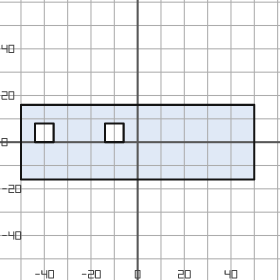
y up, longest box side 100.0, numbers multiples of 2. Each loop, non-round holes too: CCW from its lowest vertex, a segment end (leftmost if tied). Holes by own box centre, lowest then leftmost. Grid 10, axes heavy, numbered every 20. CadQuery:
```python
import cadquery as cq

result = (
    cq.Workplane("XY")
    .moveTo(-50.0, -16.0)
    .lineTo(50.0, -16.0)
    .lineTo(50.0, 16.0)
    .lineTo(-50.0, 16.0)
    .close()
    .moveTo(-44.0, 0.0)
    .lineTo(-36.0, 0.0)
    .lineTo(-36.0, 8.0)
    .lineTo(-44.0, 8.0)
    .close()
    .moveTo(-14.0, 0.0)
    .lineTo(-6.0, 0.0)
    .lineTo(-6.0, 8.0)
    .lineTo(-14.0, 8.0)
    .close()
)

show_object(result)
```